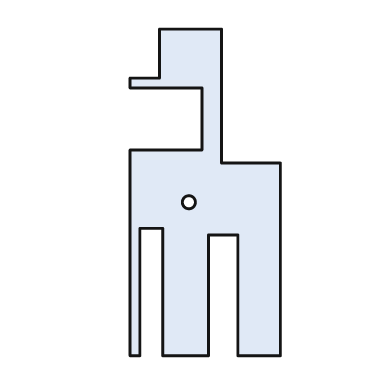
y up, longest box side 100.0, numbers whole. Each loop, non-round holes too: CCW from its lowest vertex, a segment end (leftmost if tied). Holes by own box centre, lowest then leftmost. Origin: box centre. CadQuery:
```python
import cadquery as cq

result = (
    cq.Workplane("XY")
    .moveTo(-23.0, -50.0)
    .lineTo(-20.0, -50.0)
    .lineTo(-20.0, -11.0)
    .lineTo(-13.0, -11.0)
    .lineTo(-13.0, -50.0)
    .lineTo(1.0, -50.0)
    .lineTo(1.0, -13.0)
    .lineTo(10.0, -13.0)
    .lineTo(10.0, -50.0)
    .lineTo(23.0, -50.0)
    .lineTo(23.0, 9.0)
    .lineTo(5.0, 9.0)
    .lineTo(5.0, 50.0)
    .lineTo(-14.0, 50.0)
    .lineTo(-14.0, 35.0)
    .lineTo(-23.0, 35.0)
    .lineTo(-23.0, 32.0)
    .lineTo(-1.0, 32.0)
    .lineTo(-1.0, 13.0)
    .lineTo(-23.0, 13.0)
    .close()
    .moveTo(-5.0, -3.0)
    .circle(2.0)
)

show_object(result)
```